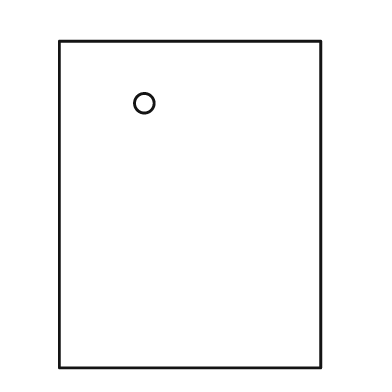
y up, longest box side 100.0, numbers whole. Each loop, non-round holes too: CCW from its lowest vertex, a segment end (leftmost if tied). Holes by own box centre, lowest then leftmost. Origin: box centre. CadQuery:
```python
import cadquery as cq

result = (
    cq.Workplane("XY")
    .moveTo(-40.0, -50.0)
    .lineTo(40.0, -50.0)
    .lineTo(40.0, 50.0)
    .lineTo(-40.0, 50.0)
    .close()
    .moveTo(-14.0, 31.0)
    .circle(3.0)
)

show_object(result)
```